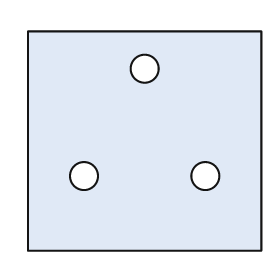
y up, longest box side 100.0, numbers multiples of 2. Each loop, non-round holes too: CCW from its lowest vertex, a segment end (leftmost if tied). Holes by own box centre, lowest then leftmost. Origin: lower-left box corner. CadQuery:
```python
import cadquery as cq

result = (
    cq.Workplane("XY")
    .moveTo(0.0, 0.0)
    .lineTo(100.0, 0.0)
    .lineTo(100.0, 94.0)
    .lineTo(0.0, 94.0)
    .close()
    .moveTo(24.0, 32.0)
    .circle(6.0)
    .moveTo(76.0, 32.0)
    .circle(6.0)
    .moveTo(50.0, 78.0)
    .circle(6.0)
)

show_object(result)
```